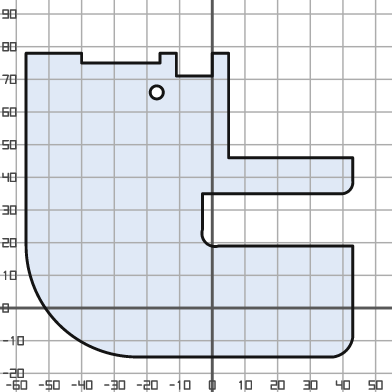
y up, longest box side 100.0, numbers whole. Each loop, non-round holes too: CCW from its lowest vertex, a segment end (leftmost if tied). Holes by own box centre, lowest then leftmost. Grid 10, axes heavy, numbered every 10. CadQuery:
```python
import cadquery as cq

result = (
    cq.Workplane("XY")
    .moveTo(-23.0, -15.0)
    .lineTo(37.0, -15.0)
    .threePointArc((41.0, -13.0), (43.0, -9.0))
    .lineTo(43.0, 19.0)
    .lineTo(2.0, 19.0)
    .threePointArc((-2.0, 20.0), (-3.0, 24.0))
    .lineTo(-3.0, 35.0)
    .lineTo(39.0, 35.0)
    .threePointArc((42.0, 36.0), (43.0, 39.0))
    .lineTo(43.0, 46.0)
    .lineTo(5.0, 46.0)
    .lineTo(5.0, 78.0)
    .lineTo(0.0, 78.0)
    .lineTo(0.0, 71.0)
    .lineTo(-11.0, 71.0)
    .lineTo(-11.0, 78.0)
    .lineTo(-16.0, 78.0)
    .lineTo(-16.0, 75.0)
    .lineTo(-40.0, 75.0)
    .lineTo(-40.0, 78.0)
    .lineTo(-57.0, 78.0)
    .lineTo(-57.0, 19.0)
    .threePointArc((-47.0, -5.0), (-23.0, -15.0))
    .close()
    .moveTo(-17.0, 66.0)
    .circle(2.0)
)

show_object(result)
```